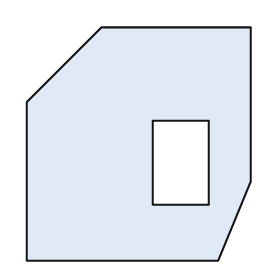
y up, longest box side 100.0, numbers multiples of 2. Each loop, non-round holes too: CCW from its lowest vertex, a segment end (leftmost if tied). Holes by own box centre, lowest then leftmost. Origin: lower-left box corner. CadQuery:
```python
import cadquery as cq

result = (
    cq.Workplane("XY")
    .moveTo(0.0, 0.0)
    .lineTo(82.0, 0.0)
    .lineTo(96.0, 34.0)
    .lineTo(96.0, 100.0)
    .lineTo(32.0, 100.0)
    .lineTo(0.0, 68.0)
    .close()
    .moveTo(54.0, 24.0)
    .lineTo(78.0, 24.0)
    .lineTo(78.0, 60.0)
    .lineTo(54.0, 60.0)
    .close()
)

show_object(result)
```